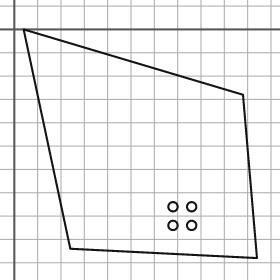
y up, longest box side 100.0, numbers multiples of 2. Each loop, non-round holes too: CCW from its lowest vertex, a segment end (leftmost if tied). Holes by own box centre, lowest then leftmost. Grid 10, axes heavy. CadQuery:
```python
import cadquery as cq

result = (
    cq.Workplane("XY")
    .moveTo(104.0, -98.0)
    .lineTo(98.0, -28.0)
    .lineTo(4.0, 0.0)
    .lineTo(24.0, -94.0)
    .close()
    .moveTo(68.0, -84.0)
    .circle(2.0)
    .moveTo(76.0, -84.0)
    .circle(2.0)
    .moveTo(68.0, -76.0)
    .circle(2.0)
    .moveTo(76.0, -76.0)
    .circle(2.0)
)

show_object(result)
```